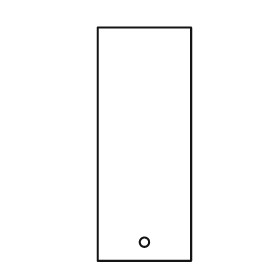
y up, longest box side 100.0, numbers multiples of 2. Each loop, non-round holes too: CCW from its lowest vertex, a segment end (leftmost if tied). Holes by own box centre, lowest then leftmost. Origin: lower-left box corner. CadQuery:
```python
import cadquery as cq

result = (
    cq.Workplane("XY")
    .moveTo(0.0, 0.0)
    .lineTo(40.0, 0.0)
    .lineTo(40.0, 100.0)
    .lineTo(0.0, 100.0)
    .close()
    .moveTo(20.0, 8.0)
    .circle(2.0)
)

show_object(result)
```